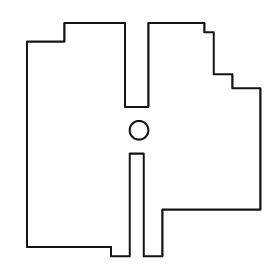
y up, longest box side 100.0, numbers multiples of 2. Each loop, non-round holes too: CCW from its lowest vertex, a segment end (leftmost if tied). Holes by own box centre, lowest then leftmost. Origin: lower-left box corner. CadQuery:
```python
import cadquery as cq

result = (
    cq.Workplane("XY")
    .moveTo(36.0, 0.0)
    .lineTo(44.0, 0.0)
    .lineTo(44.0, 44.0)
    .lineTo(50.0, 44.0)
    .lineTo(50.0, 0.0)
    .lineTo(58.0, 0.0)
    .lineTo(58.0, 20.0)
    .lineTo(100.0, 20.0)
    .lineTo(100.0, 72.0)
    .lineTo(88.0, 72.0)
    .lineTo(88.0, 78.0)
    .lineTo(80.0, 78.0)
    .lineTo(80.0, 96.0)
    .lineTo(76.0, 96.0)
    .lineTo(76.0, 100.0)
    .lineTo(52.0, 100.0)
    .lineTo(52.0, 64.0)
    .lineTo(42.0, 64.0)
    .lineTo(42.0, 100.0)
    .lineTo(16.0, 100.0)
    .lineTo(16.0, 92.0)
    .lineTo(0.0, 92.0)
    .lineTo(0.0, 4.0)
    .lineTo(36.0, 4.0)
    .close()
    .moveTo(48.0, 54.0)
    .circle(4.0)
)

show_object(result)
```